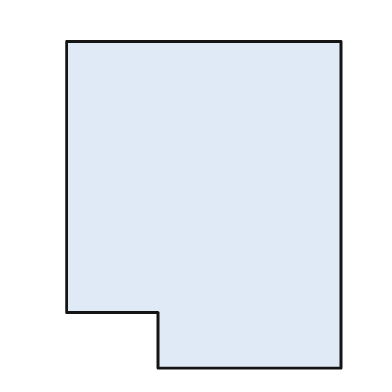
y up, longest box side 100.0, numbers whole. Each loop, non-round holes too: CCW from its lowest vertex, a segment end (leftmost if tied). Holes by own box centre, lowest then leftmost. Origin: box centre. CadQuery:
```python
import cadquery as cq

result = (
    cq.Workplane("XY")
    .moveTo(-14.0, -50.0)
    .lineTo(42.0, -50.0)
    .lineTo(42.0, 50.0)
    .lineTo(-42.0, 50.0)
    .lineTo(-42.0, -33.0)
    .lineTo(-14.0, -33.0)
    .close()
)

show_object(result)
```